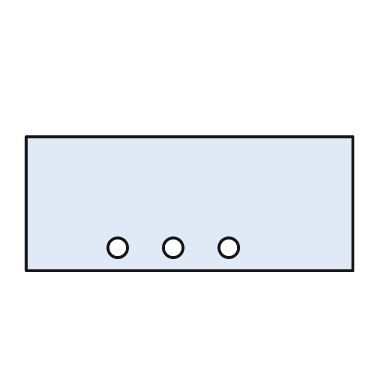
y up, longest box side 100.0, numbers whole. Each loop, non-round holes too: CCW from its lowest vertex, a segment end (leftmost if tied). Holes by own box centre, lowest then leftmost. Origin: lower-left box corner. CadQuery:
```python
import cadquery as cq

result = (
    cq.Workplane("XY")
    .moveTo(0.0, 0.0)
    .lineTo(100.0, 0.0)
    .lineTo(100.0, 41.0)
    .lineTo(0.0, 41.0)
    .close()
    .moveTo(28.0, 7.0)
    .circle(3.0)
    .moveTo(45.0, 7.0)
    .circle(3.0)
    .moveTo(62.0, 7.0)
    .circle(3.0)
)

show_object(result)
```